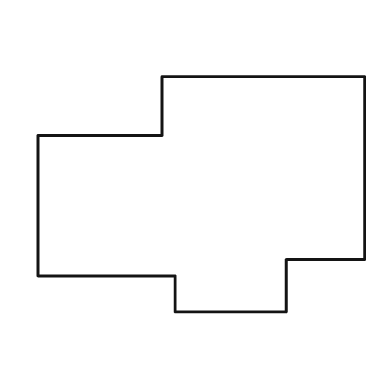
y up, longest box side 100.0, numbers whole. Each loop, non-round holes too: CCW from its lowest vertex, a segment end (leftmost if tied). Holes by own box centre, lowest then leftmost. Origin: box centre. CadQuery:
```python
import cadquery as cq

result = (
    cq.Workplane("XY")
    .moveTo(-8.0, -36.0)
    .lineTo(26.0, -36.0)
    .lineTo(26.0, -20.0)
    .lineTo(50.0, -20.0)
    .lineTo(50.0, 36.0)
    .lineTo(-12.0, 36.0)
    .lineTo(-12.0, 18.0)
    .lineTo(-50.0, 18.0)
    .lineTo(-50.0, -25.0)
    .lineTo(-8.0, -25.0)
    .close()
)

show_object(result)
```